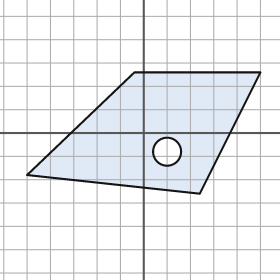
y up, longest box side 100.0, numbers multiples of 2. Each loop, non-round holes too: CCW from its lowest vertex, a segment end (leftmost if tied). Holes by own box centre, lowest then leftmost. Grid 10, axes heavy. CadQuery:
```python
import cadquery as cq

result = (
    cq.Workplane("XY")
    .moveTo(24.0, -26.0)
    .lineTo(50.0, 26.0)
    .lineTo(-4.0, 26.0)
    .lineTo(-50.0, -18.0)
    .close()
    .moveTo(10.0, -8.0)
    .circle(6.0)
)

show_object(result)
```